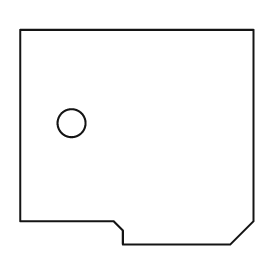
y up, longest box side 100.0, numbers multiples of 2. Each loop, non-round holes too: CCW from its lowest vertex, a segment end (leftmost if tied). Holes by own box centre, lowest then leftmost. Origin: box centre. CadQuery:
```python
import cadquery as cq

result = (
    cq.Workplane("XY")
    .moveTo(-6.0, -46.0)
    .lineTo(40.0, -46.0)
    .lineTo(50.0, -36.0)
    .lineTo(50.0, 46.0)
    .lineTo(-50.0, 46.0)
    .lineTo(-50.0, -36.0)
    .lineTo(-10.0, -36.0)
    .lineTo(-6.0, -40.0)
    .close()
    .moveTo(-28.0, 6.0)
    .circle(6.0)
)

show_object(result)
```